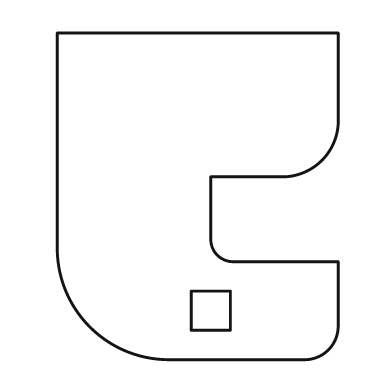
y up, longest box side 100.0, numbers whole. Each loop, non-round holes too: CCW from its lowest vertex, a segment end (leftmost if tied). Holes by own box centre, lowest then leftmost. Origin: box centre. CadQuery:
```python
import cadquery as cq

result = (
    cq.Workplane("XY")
    .moveTo(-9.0, -50.0)
    .lineTo(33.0, -50.0)
    .threePointArc((40.0, -47.0), (43.0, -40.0))
    .lineTo(43.0, -20.0)
    .lineTo(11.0, -20.0)
    .threePointArc((6.0, -18.0), (4.0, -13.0))
    .lineTo(4.0, 6.0)
    .lineTo(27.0, 6.0)
    .threePointArc((38.0, 11.0), (43.0, 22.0))
    .lineTo(43.0, 50.0)
    .lineTo(-43.0, 50.0)
    .lineTo(-43.0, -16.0)
    .threePointArc((-33.0, -40.0), (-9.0, -50.0))
    .close()
    .moveTo(-2.0, -41.0)
    .lineTo(10.0, -41.0)
    .lineTo(10.0, -29.0)
    .lineTo(-2.0, -29.0)
    .close()
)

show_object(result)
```